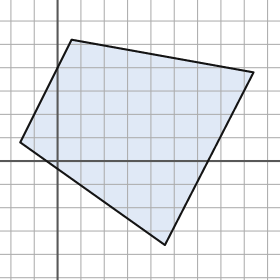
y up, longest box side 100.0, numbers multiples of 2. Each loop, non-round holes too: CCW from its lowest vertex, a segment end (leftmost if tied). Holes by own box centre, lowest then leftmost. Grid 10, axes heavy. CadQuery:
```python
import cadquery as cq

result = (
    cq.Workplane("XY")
    .moveTo(46.0, -36.0)
    .lineTo(84.0, 38.0)
    .lineTo(6.0, 52.0)
    .lineTo(-16.0, 8.0)
    .close()
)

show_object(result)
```